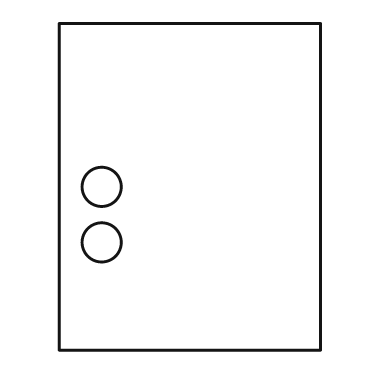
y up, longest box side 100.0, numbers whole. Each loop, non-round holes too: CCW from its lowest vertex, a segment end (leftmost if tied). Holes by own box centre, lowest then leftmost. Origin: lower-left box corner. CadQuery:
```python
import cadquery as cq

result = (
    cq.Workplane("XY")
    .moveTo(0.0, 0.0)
    .lineTo(80.0, 0.0)
    .lineTo(80.0, 100.0)
    .lineTo(0.0, 100.0)
    .close()
    .moveTo(13.0, 33.0)
    .circle(6.0)
    .moveTo(13.0, 50.0)
    .circle(6.0)
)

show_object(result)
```